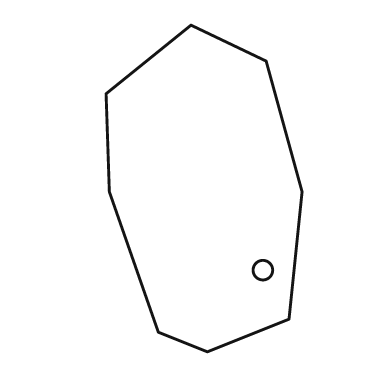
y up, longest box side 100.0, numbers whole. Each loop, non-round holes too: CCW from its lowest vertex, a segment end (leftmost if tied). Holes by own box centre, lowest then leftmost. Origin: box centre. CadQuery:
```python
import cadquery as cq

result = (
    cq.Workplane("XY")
    .moveTo(1.0, -50.0)
    .lineTo(26.0, -40.0)
    .lineTo(30.0, -1.0)
    .lineTo(19.0, 39.0)
    .lineTo(-4.0, 50.0)
    .lineTo(-30.0, 29.0)
    .lineTo(-29.0, -1.0)
    .lineTo(-14.0, -44.0)
    .close()
    .moveTo(18.0, -25.0)
    .circle(3.0)
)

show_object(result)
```